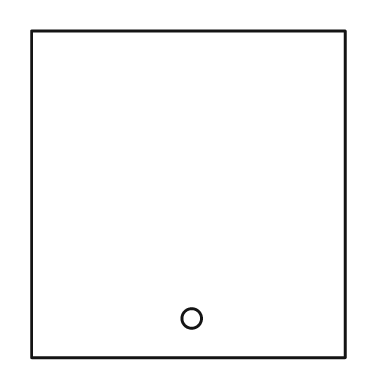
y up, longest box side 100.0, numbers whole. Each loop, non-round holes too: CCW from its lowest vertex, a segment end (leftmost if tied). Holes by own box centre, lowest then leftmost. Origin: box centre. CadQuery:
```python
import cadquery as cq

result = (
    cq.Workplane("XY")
    .moveTo(-48.0, -50.0)
    .lineTo(48.0, -50.0)
    .lineTo(48.0, 50.0)
    .lineTo(-48.0, 50.0)
    .close()
    .moveTo(1.0, -38.0)
    .circle(3.0)
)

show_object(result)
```